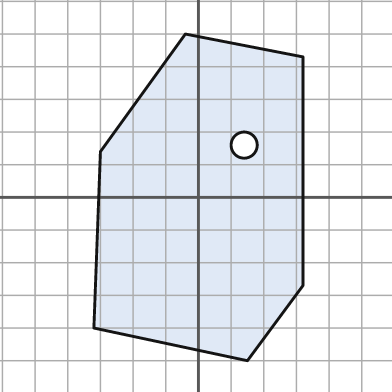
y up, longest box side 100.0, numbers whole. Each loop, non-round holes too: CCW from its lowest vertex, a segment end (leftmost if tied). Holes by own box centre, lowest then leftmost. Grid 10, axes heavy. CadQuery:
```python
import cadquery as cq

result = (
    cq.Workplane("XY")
    .moveTo(15.0, -50.0)
    .lineTo(32.0, -27.0)
    .lineTo(32.0, 43.0)
    .lineTo(-4.0, 50.0)
    .lineTo(-30.0, 14.0)
    .lineTo(-32.0, -40.0)
    .close()
    .moveTo(14.0, 16.0)
    .circle(4.0)
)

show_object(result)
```